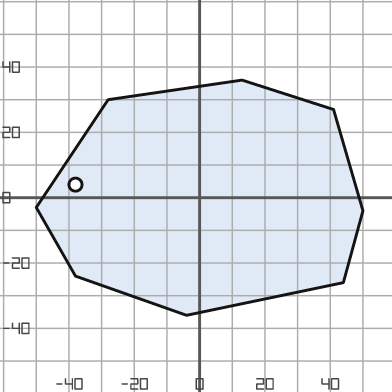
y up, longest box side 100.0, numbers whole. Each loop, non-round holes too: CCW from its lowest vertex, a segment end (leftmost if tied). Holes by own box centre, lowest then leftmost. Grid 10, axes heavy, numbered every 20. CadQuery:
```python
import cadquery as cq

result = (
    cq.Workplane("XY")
    .moveTo(-4.0, -36.0)
    .lineTo(44.0, -26.0)
    .lineTo(50.0, -4.0)
    .lineTo(41.0, 27.0)
    .lineTo(13.0, 36.0)
    .lineTo(-28.0, 30.0)
    .lineTo(-50.0, -3.0)
    .lineTo(-38.0, -24.0)
    .close()
    .moveTo(-38.0, 4.0)
    .circle(2.0)
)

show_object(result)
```